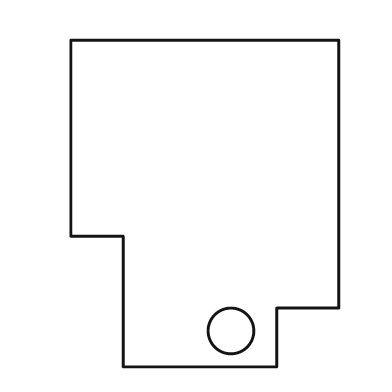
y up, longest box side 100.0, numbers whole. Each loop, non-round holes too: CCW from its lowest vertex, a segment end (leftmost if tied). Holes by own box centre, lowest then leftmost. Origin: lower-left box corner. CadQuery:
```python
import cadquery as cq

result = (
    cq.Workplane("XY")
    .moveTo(16.0, 0.0)
    .lineTo(63.0, 0.0)
    .lineTo(63.0, 18.0)
    .lineTo(82.0, 18.0)
    .lineTo(82.0, 100.0)
    .lineTo(0.0, 100.0)
    .lineTo(0.0, 40.0)
    .lineTo(16.0, 40.0)
    .close()
    .moveTo(49.0, 11.0)
    .circle(7.0)
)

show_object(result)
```